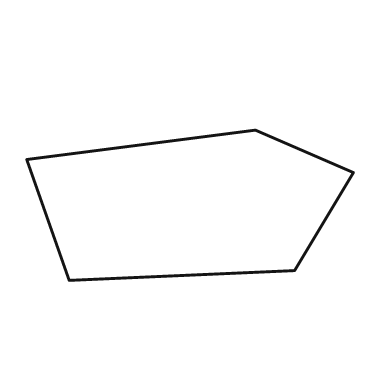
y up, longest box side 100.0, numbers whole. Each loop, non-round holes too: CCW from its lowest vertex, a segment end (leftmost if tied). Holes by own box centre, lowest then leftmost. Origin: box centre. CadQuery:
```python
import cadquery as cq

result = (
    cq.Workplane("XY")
    .moveTo(-37.0, -23.0)
    .lineTo(32.0, -20.0)
    .lineTo(50.0, 10.0)
    .lineTo(20.0, 23.0)
    .lineTo(-50.0, 14.0)
    .close()
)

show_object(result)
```